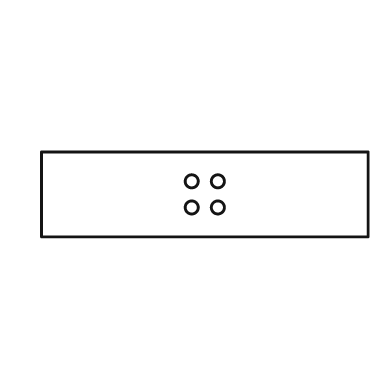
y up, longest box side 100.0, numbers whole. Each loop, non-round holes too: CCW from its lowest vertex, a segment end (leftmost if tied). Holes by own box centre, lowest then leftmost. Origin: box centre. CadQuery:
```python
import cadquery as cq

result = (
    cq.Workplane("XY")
    .moveTo(-50.0, -13.0)
    .lineTo(50.0, -13.0)
    .lineTo(50.0, 13.0)
    .lineTo(-50.0, 13.0)
    .close()
    .moveTo(-4.0, -4.0)
    .circle(2.0)
    .moveTo(4.0, -4.0)
    .circle(2.0)
    .moveTo(-4.0, 4.0)
    .circle(2.0)
    .moveTo(4.0, 4.0)
    .circle(2.0)
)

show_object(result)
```